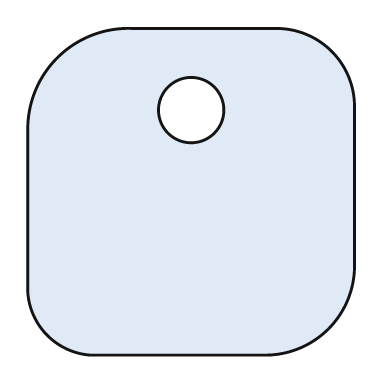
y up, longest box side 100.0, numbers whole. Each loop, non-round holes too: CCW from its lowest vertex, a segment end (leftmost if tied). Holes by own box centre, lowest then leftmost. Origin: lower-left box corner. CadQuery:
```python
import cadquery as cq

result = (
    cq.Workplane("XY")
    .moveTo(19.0, 0.0)
    .lineTo(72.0, 0.0)
    .threePointArc((92.0, 8.0), (100.0, 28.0))
    .lineTo(100.0, 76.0)
    .threePointArc((93.0, 93.0), (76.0, 100.0))
    .lineTo(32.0, 100.0)
    .threePointArc((9.0, 91.0), (0.0, 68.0))
    .lineTo(0.0, 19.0)
    .threePointArc((6.0, 6.0), (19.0, 0.0))
    .close()
    .moveTo(50.0, 75.0)
    .circle(10.0)
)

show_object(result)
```